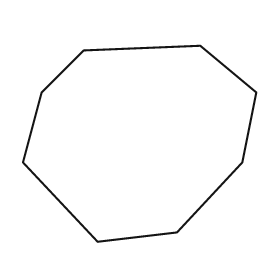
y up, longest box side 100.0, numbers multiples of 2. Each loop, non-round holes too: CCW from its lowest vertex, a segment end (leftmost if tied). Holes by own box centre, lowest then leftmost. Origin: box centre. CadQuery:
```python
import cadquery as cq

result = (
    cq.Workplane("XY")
    .moveTo(-18.0, -42.0)
    .lineTo(16.0, -38.0)
    .lineTo(44.0, -8.0)
    .lineTo(50.0, 22.0)
    .lineTo(26.0, 42.0)
    .lineTo(-24.0, 40.0)
    .lineTo(-42.0, 22.0)
    .lineTo(-50.0, -8.0)
    .close()
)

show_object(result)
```